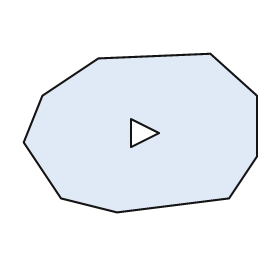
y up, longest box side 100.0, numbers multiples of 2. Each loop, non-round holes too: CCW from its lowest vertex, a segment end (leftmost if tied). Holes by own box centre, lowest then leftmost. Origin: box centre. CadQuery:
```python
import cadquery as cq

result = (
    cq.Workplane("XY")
    .moveTo(-10.0, -34.0)
    .lineTo(38.0, -28.0)
    .lineTo(50.0, -10.0)
    .lineTo(50.0, 16.0)
    .lineTo(30.0, 34.0)
    .lineTo(-18.0, 32.0)
    .lineTo(-42.0, 16.0)
    .lineTo(-50.0, -4.0)
    .lineTo(-34.0, -28.0)
    .close()
    .moveTo(-4.0, -6.0)
    .lineTo(8.0, 0.0)
    .lineTo(-4.0, 6.0)
    .close()
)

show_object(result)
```